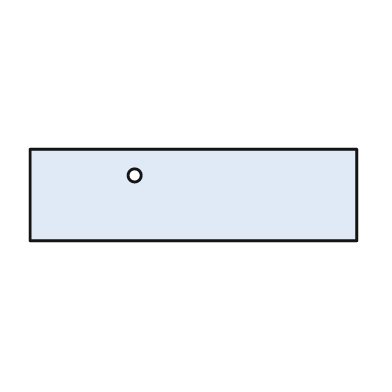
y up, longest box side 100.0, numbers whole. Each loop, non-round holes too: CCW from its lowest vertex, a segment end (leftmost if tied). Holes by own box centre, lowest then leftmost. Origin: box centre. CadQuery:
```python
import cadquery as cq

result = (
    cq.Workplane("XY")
    .moveTo(-50.0, -14.0)
    .lineTo(50.0, -14.0)
    .lineTo(50.0, 14.0)
    .lineTo(-50.0, 14.0)
    .close()
    .moveTo(-18.0, 6.0)
    .circle(2.0)
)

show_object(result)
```